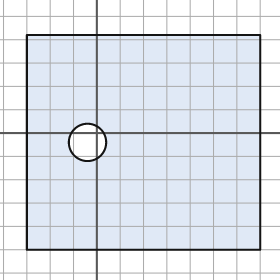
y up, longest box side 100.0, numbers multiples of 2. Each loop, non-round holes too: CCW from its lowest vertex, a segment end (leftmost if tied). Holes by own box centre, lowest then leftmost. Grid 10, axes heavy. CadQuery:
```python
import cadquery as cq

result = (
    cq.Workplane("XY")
    .moveTo(-30.0, -50.0)
    .lineTo(70.0, -50.0)
    .lineTo(70.0, 42.0)
    .lineTo(-30.0, 42.0)
    .close()
    .moveTo(-4.0, -4.0)
    .circle(8.0)
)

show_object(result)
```